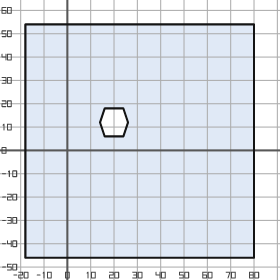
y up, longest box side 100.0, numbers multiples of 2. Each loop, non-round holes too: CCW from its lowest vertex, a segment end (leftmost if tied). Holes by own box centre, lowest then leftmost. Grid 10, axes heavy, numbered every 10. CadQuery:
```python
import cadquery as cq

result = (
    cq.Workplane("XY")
    .moveTo(-18.0, -46.0)
    .lineTo(80.0, -46.0)
    .lineTo(80.0, 54.0)
    .lineTo(-18.0, 54.0)
    .close()
    .moveTo(16.0, 6.0)
    .lineTo(24.0, 6.0)
    .lineTo(26.0, 12.0)
    .lineTo(24.0, 18.0)
    .lineTo(16.0, 18.0)
    .lineTo(14.0, 12.0)
    .close()
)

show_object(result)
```